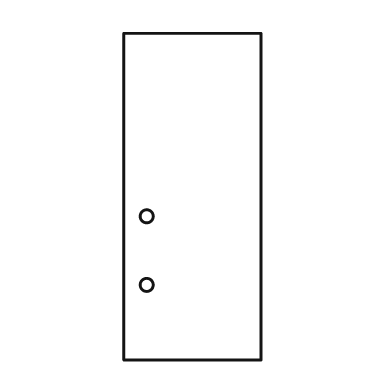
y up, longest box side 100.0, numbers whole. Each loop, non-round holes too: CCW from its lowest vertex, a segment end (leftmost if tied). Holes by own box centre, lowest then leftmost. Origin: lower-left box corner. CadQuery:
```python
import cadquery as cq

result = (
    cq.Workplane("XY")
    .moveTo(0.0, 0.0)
    .lineTo(42.0, 0.0)
    .lineTo(42.0, 100.0)
    .lineTo(0.0, 100.0)
    .close()
    .moveTo(7.0, 23.0)
    .circle(2.0)
    .moveTo(7.0, 44.0)
    .circle(2.0)
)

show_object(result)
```